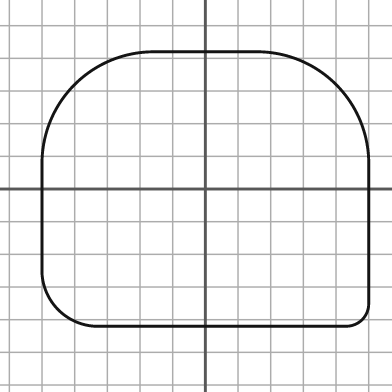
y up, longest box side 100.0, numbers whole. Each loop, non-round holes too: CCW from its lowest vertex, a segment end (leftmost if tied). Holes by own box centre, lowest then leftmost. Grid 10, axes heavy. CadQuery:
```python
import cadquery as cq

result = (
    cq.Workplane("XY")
    .moveTo(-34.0, -42.0)
    .lineTo(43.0, -42.0)
    .threePointArc((48.0, -40.0), (50.0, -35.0))
    .lineTo(50.0, 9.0)
    .threePointArc((40.0, 32.0), (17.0, 42.0))
    .lineTo(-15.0, 42.0)
    .threePointArc((-40.0, 32.0), (-50.0, 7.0))
    .lineTo(-50.0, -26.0)
    .threePointArc((-45.0, -37.0), (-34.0, -42.0))
    .close()
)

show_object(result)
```